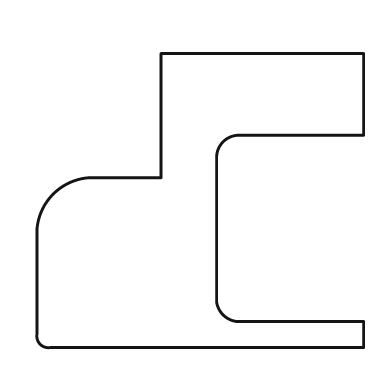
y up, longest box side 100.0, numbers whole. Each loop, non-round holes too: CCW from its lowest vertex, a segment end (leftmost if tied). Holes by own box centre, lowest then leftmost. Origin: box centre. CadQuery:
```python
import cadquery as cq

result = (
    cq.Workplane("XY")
    .moveTo(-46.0, -45.0)
    .lineTo(50.0, -45.0)
    .lineTo(50.0, -37.0)
    .lineTo(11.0, -37.0)
    .threePointArc((7.0, -35.0), (5.0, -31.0))
    .lineTo(5.0, 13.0)
    .threePointArc((7.0, 18.0), (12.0, 20.0))
    .lineTo(50.0, 20.0)
    .lineTo(50.0, 45.0)
    .lineTo(-12.0, 45.0)
    .lineTo(-12.0, 7.0)
    .lineTo(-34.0, 7.0)
    .threePointArc((-45.0, 2.0), (-50.0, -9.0))
    .lineTo(-50.0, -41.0)
    .threePointArc((-49.0, -44.0), (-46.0, -45.0))
    .close()
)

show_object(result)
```